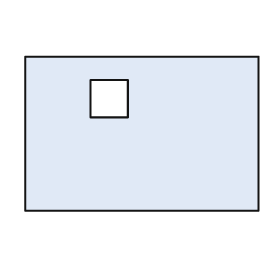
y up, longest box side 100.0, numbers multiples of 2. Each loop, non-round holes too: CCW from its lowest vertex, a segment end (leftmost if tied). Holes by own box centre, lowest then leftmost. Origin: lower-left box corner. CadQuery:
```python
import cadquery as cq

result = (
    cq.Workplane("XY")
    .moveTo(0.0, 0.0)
    .lineTo(100.0, 0.0)
    .lineTo(100.0, 66.0)
    .lineTo(0.0, 66.0)
    .close()
    .moveTo(28.0, 40.0)
    .lineTo(44.0, 40.0)
    .lineTo(44.0, 56.0)
    .lineTo(28.0, 56.0)
    .close()
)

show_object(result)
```